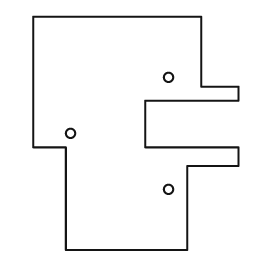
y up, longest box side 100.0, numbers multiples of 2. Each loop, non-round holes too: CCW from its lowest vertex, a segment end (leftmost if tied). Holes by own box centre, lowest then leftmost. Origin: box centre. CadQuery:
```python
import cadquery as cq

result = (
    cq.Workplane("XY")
    .moveTo(-30.0, -50.0)
    .lineTo(22.0, -50.0)
    .lineTo(22.0, -14.0)
    .lineTo(44.0, -14.0)
    .lineTo(44.0, -6.0)
    .lineTo(4.0, -6.0)
    .lineTo(4.0, 14.0)
    .lineTo(44.0, 14.0)
    .lineTo(44.0, 20.0)
    .lineTo(28.0, 20.0)
    .lineTo(28.0, 50.0)
    .lineTo(-44.0, 50.0)
    .lineTo(-44.0, -6.0)
    .lineTo(-30.0, -6.0)
    .close()
    .moveTo(14.0, -24.0)
    .circle(2.0)
    .moveTo(-28.0, 0.0)
    .circle(2.0)
    .moveTo(14.0, 24.0)
    .circle(2.0)
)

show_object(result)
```